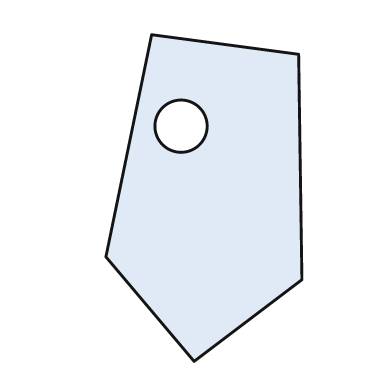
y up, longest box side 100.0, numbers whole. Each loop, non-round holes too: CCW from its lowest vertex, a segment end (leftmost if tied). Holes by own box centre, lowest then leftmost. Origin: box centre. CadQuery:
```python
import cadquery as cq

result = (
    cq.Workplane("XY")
    .moveTo(-3.0, -50.0)
    .lineTo(30.0, -25.0)
    .lineTo(29.0, 44.0)
    .lineTo(-16.0, 50.0)
    .lineTo(-30.0, -18.0)
    .close()
    .moveTo(-7.0, 22.0)
    .circle(8.0)
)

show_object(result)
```